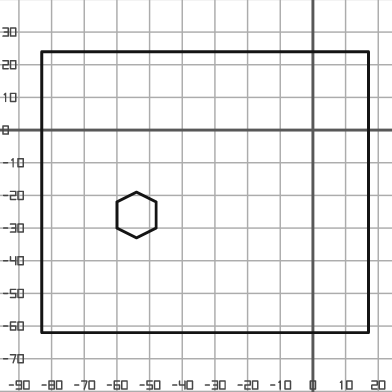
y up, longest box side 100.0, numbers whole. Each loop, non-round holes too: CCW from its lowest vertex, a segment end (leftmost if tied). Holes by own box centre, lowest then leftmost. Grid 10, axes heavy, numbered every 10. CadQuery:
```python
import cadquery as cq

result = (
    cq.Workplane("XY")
    .moveTo(-83.0, -62.0)
    .lineTo(17.0, -62.0)
    .lineTo(17.0, 24.0)
    .lineTo(-83.0, 24.0)
    .close()
    .moveTo(-54.0, -33.0)
    .lineTo(-48.0, -30.0)
    .lineTo(-48.0, -22.0)
    .lineTo(-54.0, -19.0)
    .lineTo(-60.0, -22.0)
    .lineTo(-60.0, -30.0)
    .close()
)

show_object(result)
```